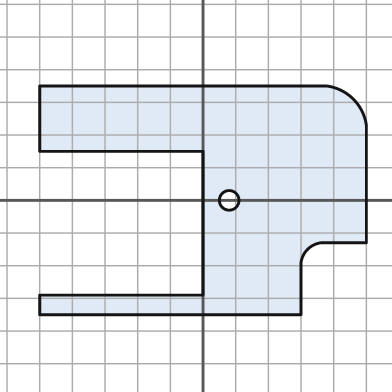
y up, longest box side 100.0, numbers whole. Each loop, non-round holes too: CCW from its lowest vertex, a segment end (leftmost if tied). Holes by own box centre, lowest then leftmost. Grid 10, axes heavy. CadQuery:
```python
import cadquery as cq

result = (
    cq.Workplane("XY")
    .moveTo(-50.0, -35.0)
    .lineTo(30.0, -35.0)
    .lineTo(30.0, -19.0)
    .threePointArc((32.0, -15.0), (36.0, -13.0))
    .lineTo(50.0, -13.0)
    .lineTo(50.0, 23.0)
    .threePointArc((46.0, 31.0), (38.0, 35.0))
    .lineTo(-50.0, 35.0)
    .lineTo(-50.0, 15.0)
    .lineTo(0.0, 15.0)
    .lineTo(0.0, -29.0)
    .lineTo(-50.0, -29.0)
    .close()
    .moveTo(8.0, 0.0)
    .circle(3.0)
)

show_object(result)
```